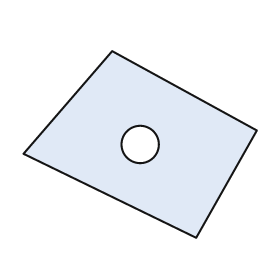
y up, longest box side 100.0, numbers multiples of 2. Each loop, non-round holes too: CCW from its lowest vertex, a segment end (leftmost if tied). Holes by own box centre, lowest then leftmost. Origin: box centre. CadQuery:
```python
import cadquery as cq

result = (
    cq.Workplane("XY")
    .moveTo(24.0, -40.0)
    .lineTo(50.0, 6.0)
    .lineTo(-12.0, 40.0)
    .lineTo(-50.0, -4.0)
    .close()
    .moveTo(0.0, 0.0)
    .circle(8.0)
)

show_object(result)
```